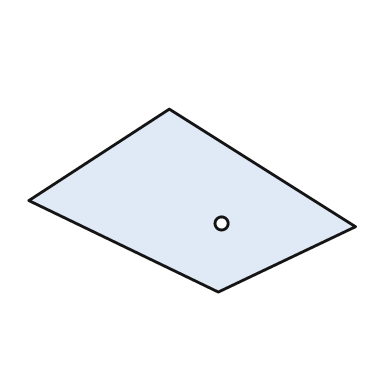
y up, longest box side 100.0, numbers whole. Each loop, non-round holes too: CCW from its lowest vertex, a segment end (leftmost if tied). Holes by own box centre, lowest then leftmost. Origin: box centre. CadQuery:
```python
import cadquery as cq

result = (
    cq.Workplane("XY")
    .moveTo(8.0, -28.0)
    .lineTo(50.0, -8.0)
    .lineTo(-7.0, 28.0)
    .lineTo(-50.0, 0.0)
    .close()
    .moveTo(9.0, -7.0)
    .circle(2.0)
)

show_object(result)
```